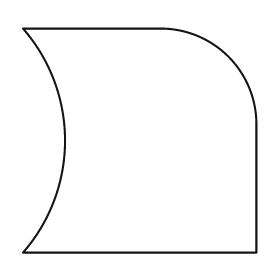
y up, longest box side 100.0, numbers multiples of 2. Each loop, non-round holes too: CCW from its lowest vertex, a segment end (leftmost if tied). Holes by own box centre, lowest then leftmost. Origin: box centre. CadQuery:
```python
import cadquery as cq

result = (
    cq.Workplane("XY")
    .moveTo(-50.0, -48.0)
    .lineTo(50.0, -48.0)
    .lineTo(50.0, 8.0)
    .threePointArc((38.0, 36.0), (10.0, 48.0))
    .lineTo(-50.0, 48.0)
    .threePointArc((-32.0, 0.0), (-50.0, -48.0))
    .close()
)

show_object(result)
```